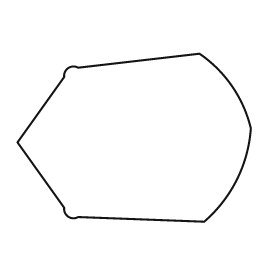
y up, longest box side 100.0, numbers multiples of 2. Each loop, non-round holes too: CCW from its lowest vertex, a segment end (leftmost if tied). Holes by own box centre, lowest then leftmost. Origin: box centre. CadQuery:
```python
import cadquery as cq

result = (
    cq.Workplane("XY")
    .moveTo(30.0, -36.0)
    .threePointArc((44.0, -18.0), (50.0, 4.0))
    .threePointArc((42.0, 22.0), (28.0, 36.0))
    .lineTo(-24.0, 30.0)
    .threePointArc((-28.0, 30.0), (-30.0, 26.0))
    .lineTo(-50.0, -2.0)
    .lineTo(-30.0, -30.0)
    .threePointArc((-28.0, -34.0), (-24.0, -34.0))
    .close()
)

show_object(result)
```